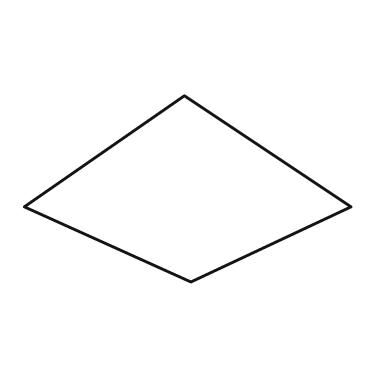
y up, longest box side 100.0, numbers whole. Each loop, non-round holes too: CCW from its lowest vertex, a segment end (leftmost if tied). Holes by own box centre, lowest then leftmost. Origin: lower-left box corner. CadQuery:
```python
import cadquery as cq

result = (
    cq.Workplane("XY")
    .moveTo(51.0, 0.0)
    .lineTo(100.0, 23.0)
    .lineTo(49.0, 57.0)
    .lineTo(0.0, 23.0)
    .close()
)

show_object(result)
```